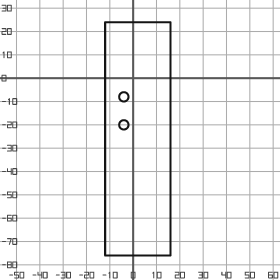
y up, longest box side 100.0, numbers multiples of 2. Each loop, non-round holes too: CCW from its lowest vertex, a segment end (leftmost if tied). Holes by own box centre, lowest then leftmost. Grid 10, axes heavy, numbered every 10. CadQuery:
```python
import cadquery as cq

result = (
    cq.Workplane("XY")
    .moveTo(-12.0, -76.0)
    .lineTo(16.0, -76.0)
    .lineTo(16.0, 24.0)
    .lineTo(-12.0, 24.0)
    .close()
    .moveTo(-4.0, -20.0)
    .circle(2.0)
    .moveTo(-4.0, -8.0)
    .circle(2.0)
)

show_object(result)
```